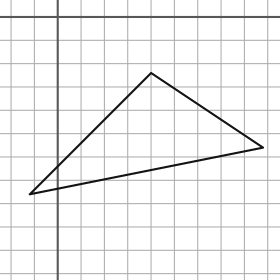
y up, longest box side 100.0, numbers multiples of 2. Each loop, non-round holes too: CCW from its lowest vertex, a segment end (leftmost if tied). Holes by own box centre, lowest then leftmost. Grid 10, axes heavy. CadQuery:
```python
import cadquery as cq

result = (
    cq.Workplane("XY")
    .moveTo(-12.0, -76.0)
    .lineTo(88.0, -56.0)
    .lineTo(40.0, -24.0)
    .close()
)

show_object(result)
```